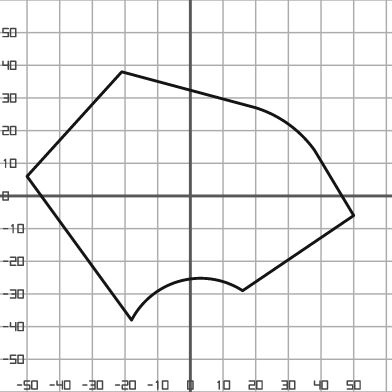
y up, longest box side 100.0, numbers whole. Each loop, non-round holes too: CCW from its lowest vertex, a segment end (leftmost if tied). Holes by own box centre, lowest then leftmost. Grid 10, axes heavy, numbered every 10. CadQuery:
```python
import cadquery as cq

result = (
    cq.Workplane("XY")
    .moveTo(-18.0, -38.0)
    .threePointArc((-3.0, -26.0), (16.0, -29.0))
    .lineTo(50.0, -6.0)
    .lineTo(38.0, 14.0)
    .threePointArc((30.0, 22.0), (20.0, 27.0))
    .lineTo(-21.0, 38.0)
    .lineTo(-50.0, 6.0)
    .close()
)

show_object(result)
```